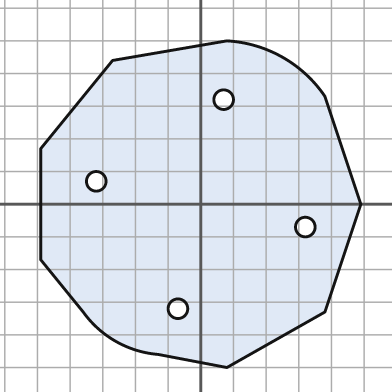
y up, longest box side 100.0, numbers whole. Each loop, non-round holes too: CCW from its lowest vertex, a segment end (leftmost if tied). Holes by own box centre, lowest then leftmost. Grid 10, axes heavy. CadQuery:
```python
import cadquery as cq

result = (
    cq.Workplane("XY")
    .moveTo(8.0, -50.0)
    .lineTo(38.0, -33.0)
    .lineTo(49.0, 0.0)
    .lineTo(38.0, 33.0)
    .threePointArc((25.0, 45.0), (8.0, 50.0))
    .lineTo(-27.0, 44.0)
    .lineTo(-49.0, 17.0)
    .lineTo(-49.0, -17.0)
    .lineTo(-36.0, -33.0)
    .threePointArc((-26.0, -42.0), (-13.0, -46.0))
    .close()
    .moveTo(-7.0, -32.0)
    .circle(3.0)
    .moveTo(32.0, -7.0)
    .circle(3.0)
    .moveTo(-32.0, 7.0)
    .circle(3.0)
    .moveTo(7.0, 32.0)
    .circle(3.0)
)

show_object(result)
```